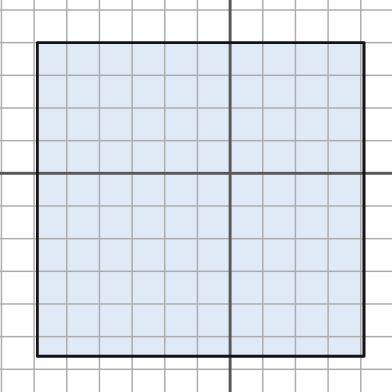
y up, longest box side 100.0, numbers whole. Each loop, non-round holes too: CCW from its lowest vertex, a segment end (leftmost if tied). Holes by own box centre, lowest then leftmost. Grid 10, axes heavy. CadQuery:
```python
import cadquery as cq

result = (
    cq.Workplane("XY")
    .moveTo(-59.0, -56.0)
    .lineTo(41.0, -56.0)
    .lineTo(41.0, 40.0)
    .lineTo(-59.0, 40.0)
    .close()
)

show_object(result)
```